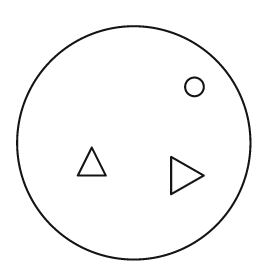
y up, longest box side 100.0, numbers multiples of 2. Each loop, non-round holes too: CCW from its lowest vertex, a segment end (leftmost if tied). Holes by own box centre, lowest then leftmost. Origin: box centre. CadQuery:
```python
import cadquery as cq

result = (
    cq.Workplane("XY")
    .moveTo(0.0, 0.0)
    .circle(50.0)
    .moveTo(16.0, -22.0)
    .lineTo(30.0, -14.0)
    .lineTo(16.0, -6.0)
    .close()
    .moveTo(-24.0, -14.0)
    .lineTo(-12.0, -14.0)
    .lineTo(-18.0, -2.0)
    .close()
    .moveTo(26.0, 24.0)
    .circle(4.0)
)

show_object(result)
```